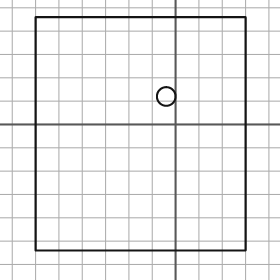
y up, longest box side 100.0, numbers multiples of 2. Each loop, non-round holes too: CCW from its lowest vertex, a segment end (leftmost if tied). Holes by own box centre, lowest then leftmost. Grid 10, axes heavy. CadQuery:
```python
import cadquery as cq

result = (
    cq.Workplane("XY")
    .moveTo(-60.0, -54.0)
    .lineTo(30.0, -54.0)
    .lineTo(30.0, 46.0)
    .lineTo(-60.0, 46.0)
    .close()
    .moveTo(-4.0, 12.0)
    .circle(4.0)
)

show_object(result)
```